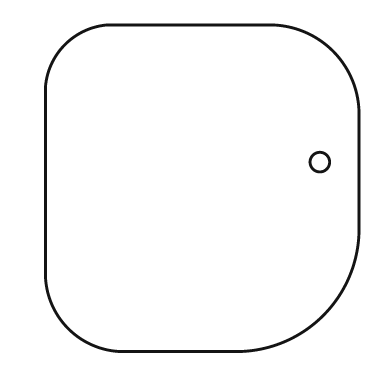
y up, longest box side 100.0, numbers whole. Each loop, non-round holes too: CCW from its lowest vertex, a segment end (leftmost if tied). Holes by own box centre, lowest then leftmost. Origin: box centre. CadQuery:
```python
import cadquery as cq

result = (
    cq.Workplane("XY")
    .moveTo(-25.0, -50.0)
    .lineTo(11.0, -50.0)
    .threePointArc((37.0, -39.0), (48.0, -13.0))
    .lineTo(48.0, 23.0)
    .threePointArc((40.0, 42.0), (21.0, 50.0))
    .lineTo(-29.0, 50.0)
    .threePointArc((-42.0, 44.0), (-48.0, 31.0))
    .lineTo(-48.0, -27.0)
    .threePointArc((-41.0, -43.0), (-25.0, -50.0))
    .close()
    .moveTo(36.0, 8.0)
    .circle(3.0)
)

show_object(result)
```